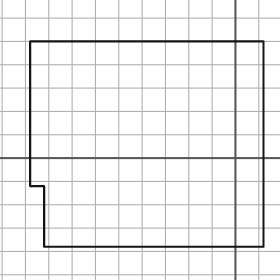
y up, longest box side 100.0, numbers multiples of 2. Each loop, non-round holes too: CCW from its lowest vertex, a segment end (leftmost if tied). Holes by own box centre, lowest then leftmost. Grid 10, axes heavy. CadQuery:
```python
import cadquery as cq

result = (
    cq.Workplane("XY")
    .moveTo(-82.0, -38.0)
    .lineTo(12.0, -38.0)
    .lineTo(12.0, 50.0)
    .lineTo(-88.0, 50.0)
    .lineTo(-88.0, -12.0)
    .lineTo(-82.0, -12.0)
    .close()
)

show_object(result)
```